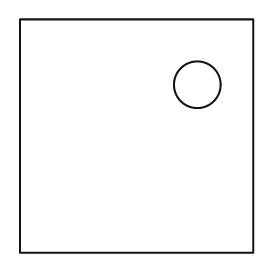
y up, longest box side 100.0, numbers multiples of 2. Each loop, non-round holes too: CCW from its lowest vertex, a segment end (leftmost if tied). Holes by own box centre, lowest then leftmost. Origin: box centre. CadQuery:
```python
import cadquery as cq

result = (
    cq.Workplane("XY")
    .moveTo(-50.0, -50.0)
    .lineTo(50.0, -50.0)
    .lineTo(50.0, 50.0)
    .lineTo(-50.0, 50.0)
    .close()
    .moveTo(26.0, 22.0)
    .circle(10.0)
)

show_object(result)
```